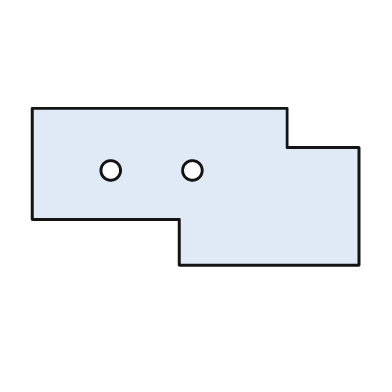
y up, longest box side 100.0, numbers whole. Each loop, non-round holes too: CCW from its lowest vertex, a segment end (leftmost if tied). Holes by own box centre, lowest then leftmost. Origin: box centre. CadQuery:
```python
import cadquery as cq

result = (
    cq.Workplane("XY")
    .moveTo(-5.0, -24.0)
    .lineTo(50.0, -24.0)
    .lineTo(50.0, 12.0)
    .lineTo(28.0, 12.0)
    .lineTo(28.0, 24.0)
    .lineTo(-50.0, 24.0)
    .lineTo(-50.0, -10.0)
    .lineTo(-5.0, -10.0)
    .close()
    .moveTo(-26.0, 5.0)
    .circle(3.0)
    .moveTo(-1.0, 5.0)
    .circle(3.0)
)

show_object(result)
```